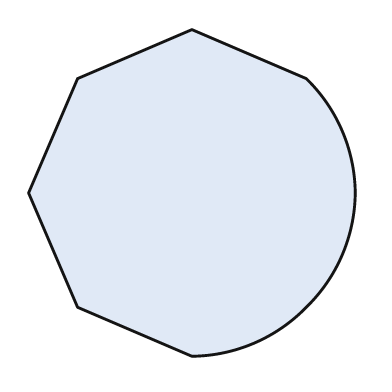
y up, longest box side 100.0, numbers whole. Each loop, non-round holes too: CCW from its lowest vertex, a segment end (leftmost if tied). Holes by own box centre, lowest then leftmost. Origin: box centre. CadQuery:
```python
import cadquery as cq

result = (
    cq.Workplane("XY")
    .moveTo(0.0, -50.0)
    .threePointArc((19.0, -46.0), (35.0, -35.0))
    .threePointArc((46.0, -19.0), (50.0, 0.0))
    .threePointArc((46.0, 19.0), (35.0, 35.0))
    .lineTo(0.0, 50.0)
    .lineTo(-35.0, 35.0)
    .lineTo(-50.0, 0.0)
    .lineTo(-35.0, -35.0)
    .close()
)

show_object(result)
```